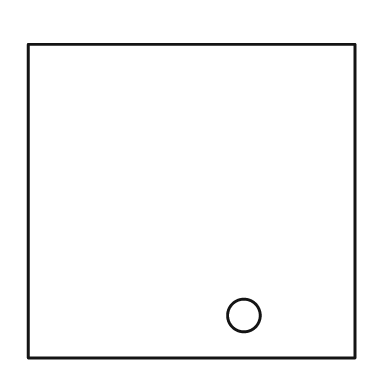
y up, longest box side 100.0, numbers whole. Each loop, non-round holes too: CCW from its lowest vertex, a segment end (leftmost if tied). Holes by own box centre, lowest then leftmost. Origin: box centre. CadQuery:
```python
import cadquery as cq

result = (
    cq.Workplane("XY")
    .moveTo(-50.0, -48.0)
    .lineTo(50.0, -48.0)
    .lineTo(50.0, 48.0)
    .lineTo(-50.0, 48.0)
    .close()
    .moveTo(16.0, -35.0)
    .circle(5.0)
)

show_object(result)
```